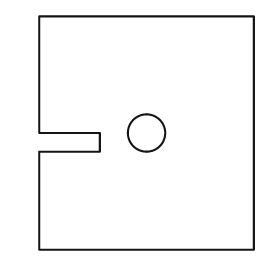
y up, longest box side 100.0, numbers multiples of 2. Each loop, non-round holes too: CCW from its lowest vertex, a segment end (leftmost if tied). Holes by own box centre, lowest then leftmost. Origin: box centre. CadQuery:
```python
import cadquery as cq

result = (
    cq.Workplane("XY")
    .moveTo(-46.0, -50.0)
    .lineTo(46.0, -50.0)
    .lineTo(46.0, 50.0)
    .lineTo(-46.0, 50.0)
    .lineTo(-46.0, 0.0)
    .lineTo(-20.0, 0.0)
    .lineTo(-20.0, -8.0)
    .lineTo(-46.0, -8.0)
    .close()
    .moveTo(0.0, 0.0)
    .circle(8.0)
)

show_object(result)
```